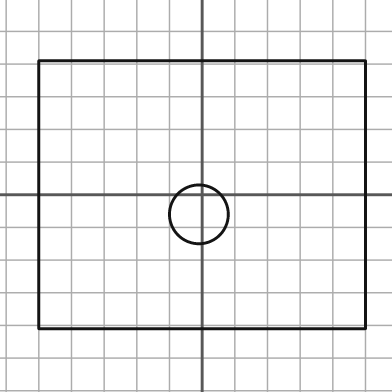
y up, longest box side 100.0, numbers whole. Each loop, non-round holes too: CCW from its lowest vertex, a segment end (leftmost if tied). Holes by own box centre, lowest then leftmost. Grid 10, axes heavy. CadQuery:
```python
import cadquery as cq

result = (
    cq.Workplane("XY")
    .moveTo(-50.0, -41.0)
    .lineTo(50.0, -41.0)
    .lineTo(50.0, 41.0)
    .lineTo(-50.0, 41.0)
    .close()
    .moveTo(-1.0, -6.0)
    .circle(9.0)
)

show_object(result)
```